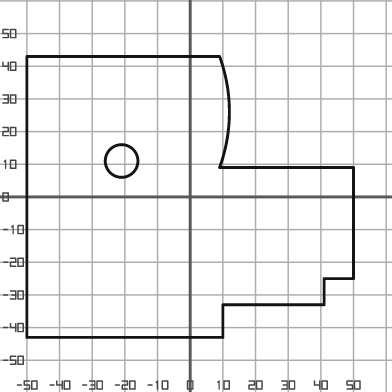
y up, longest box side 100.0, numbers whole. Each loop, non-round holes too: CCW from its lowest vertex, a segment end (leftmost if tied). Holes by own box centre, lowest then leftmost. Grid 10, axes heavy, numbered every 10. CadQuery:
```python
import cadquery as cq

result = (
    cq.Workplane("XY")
    .moveTo(-50.0, -43.0)
    .lineTo(10.0, -43.0)
    .lineTo(10.0, -33.0)
    .lineTo(41.0, -33.0)
    .lineTo(41.0, -25.0)
    .lineTo(50.0, -25.0)
    .lineTo(50.0, 9.0)
    .lineTo(9.0, 9.0)
    .threePointArc((12.0, 26.0), (9.0, 43.0))
    .lineTo(-50.0, 43.0)
    .close()
    .moveTo(-21.0, 11.0)
    .circle(5.0)
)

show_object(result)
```